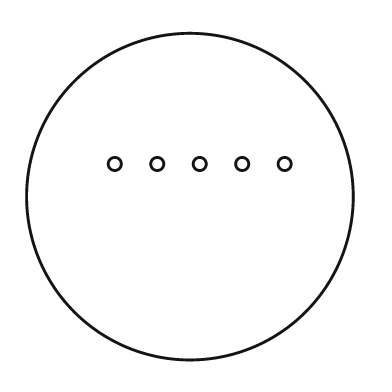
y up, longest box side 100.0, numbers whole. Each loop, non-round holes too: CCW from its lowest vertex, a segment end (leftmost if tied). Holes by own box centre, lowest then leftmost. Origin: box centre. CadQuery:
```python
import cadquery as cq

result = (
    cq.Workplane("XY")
    .moveTo(0.0, 0.0)
    .circle(50.0)
    .moveTo(-23.0, 10.0)
    .circle(2.0)
    .moveTo(-10.0, 10.0)
    .circle(2.0)
    .moveTo(3.0, 10.0)
    .circle(2.0)
    .moveTo(16.0, 10.0)
    .circle(2.0)
    .moveTo(29.0, 10.0)
    .circle(2.0)
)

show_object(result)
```